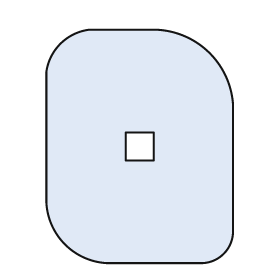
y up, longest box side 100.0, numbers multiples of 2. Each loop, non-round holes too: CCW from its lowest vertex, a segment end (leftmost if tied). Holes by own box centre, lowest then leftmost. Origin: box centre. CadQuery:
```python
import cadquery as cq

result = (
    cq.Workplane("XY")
    .moveTo(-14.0, -50.0)
    .lineTo(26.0, -50.0)
    .threePointArc((36.0, -46.0), (40.0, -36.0))
    .lineTo(40.0, 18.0)
    .threePointArc((30.0, 40.0), (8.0, 50.0))
    .lineTo(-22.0, 50.0)
    .threePointArc((-34.0, 44.0), (-40.0, 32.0))
    .lineTo(-40.0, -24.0)
    .threePointArc((-32.0, -42.0), (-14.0, -50.0))
    .close()
    .moveTo(-6.0, -6.0)
    .lineTo(6.0, -6.0)
    .lineTo(6.0, 6.0)
    .lineTo(-6.0, 6.0)
    .close()
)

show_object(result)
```